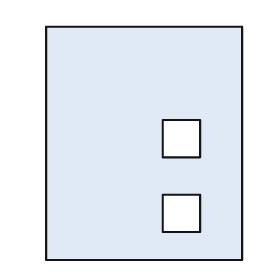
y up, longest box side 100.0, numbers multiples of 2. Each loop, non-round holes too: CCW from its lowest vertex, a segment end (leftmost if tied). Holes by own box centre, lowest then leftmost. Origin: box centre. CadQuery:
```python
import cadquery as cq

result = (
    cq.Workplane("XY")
    .moveTo(-42.0, -50.0)
    .lineTo(42.0, -50.0)
    .lineTo(42.0, 50.0)
    .lineTo(-42.0, 50.0)
    .close()
    .moveTo(8.0, -38.0)
    .lineTo(24.0, -38.0)
    .lineTo(24.0, -22.0)
    .lineTo(8.0, -22.0)
    .close()
    .moveTo(8.0, -6.0)
    .lineTo(24.0, -6.0)
    .lineTo(24.0, 10.0)
    .lineTo(8.0, 10.0)
    .close()
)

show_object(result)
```